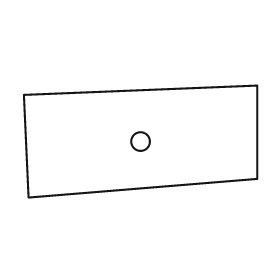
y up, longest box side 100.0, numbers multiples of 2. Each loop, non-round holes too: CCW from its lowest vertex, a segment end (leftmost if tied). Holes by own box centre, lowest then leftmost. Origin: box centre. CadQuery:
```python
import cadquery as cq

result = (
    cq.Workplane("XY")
    .moveTo(-48.0, -24.0)
    .lineTo(50.0, -16.0)
    .lineTo(50.0, 24.0)
    .lineTo(-50.0, 20.0)
    .close()
    .moveTo(0.0, 0.0)
    .circle(4.0)
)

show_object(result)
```